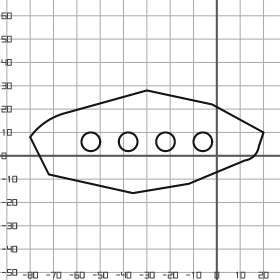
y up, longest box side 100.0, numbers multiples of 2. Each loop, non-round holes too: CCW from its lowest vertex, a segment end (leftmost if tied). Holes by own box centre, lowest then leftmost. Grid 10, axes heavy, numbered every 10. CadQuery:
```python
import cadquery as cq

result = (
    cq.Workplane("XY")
    .moveTo(-36.0, -16.0)
    .lineTo(-12.0, -12.0)
    .lineTo(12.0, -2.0)
    .threePointArc((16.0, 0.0), (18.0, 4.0))
    .lineTo(20.0, 10.0)
    .lineTo(-2.0, 22.0)
    .lineTo(-30.0, 28.0)
    .lineTo(-66.0, 18.0)
    .threePointArc((-74.0, 14.0), (-80.0, 8.0))
    .lineTo(-72.0, -8.0)
    .close()
    .moveTo(-54.0, 6.0)
    .circle(4.0)
    .moveTo(-38.0, 6.0)
    .circle(4.0)
    .moveTo(-22.0, 6.0)
    .circle(4.0)
    .moveTo(-6.0, 6.0)
    .circle(4.0)
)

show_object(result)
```